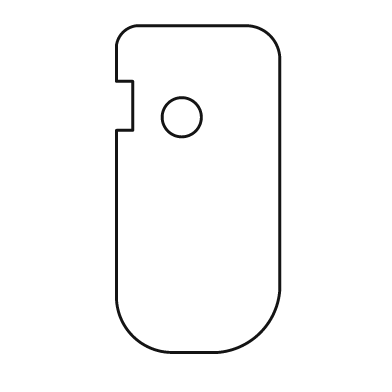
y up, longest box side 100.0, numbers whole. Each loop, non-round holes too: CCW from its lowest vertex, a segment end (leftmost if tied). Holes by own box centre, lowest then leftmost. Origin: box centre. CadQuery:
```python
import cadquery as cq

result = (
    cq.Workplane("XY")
    .moveTo(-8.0, -50.0)
    .lineTo(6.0, -50.0)
    .threePointArc((19.0, -44.0), (25.0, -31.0))
    .lineTo(25.0, 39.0)
    .threePointArc((22.0, 47.0), (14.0, 50.0))
    .lineTo(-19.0, 50.0)
    .threePointArc((-23.0, 48.0), (-25.0, 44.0))
    .lineTo(-25.0, 33.0)
    .lineTo(-20.0, 33.0)
    .lineTo(-20.0, 18.0)
    .lineTo(-25.0, 18.0)
    .lineTo(-25.0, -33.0)
    .threePointArc((-20.0, -45.0), (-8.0, -50.0))
    .close()
    .moveTo(-5.0, 22.0)
    .circle(6.0)
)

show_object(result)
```